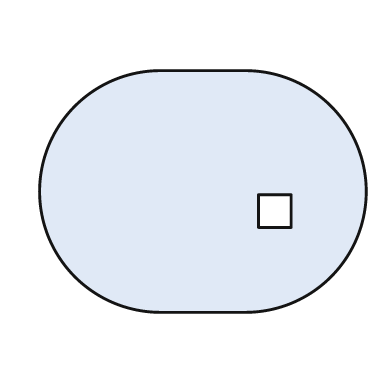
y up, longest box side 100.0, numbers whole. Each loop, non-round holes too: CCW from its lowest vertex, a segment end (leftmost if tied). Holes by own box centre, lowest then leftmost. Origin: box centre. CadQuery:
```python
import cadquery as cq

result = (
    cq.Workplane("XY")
    .moveTo(-13.0, -37.0)
    .lineTo(13.0, -37.0)
    .threePointArc((50.0, 0.0), (13.0, 37.0))
    .lineTo(-13.0, 37.0)
    .threePointArc((-50.0, 0.0), (-13.0, -37.0))
    .close()
    .moveTo(17.0, -11.0)
    .lineTo(27.0, -11.0)
    .lineTo(27.0, -1.0)
    .lineTo(17.0, -1.0)
    .close()
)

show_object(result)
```